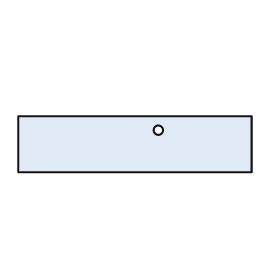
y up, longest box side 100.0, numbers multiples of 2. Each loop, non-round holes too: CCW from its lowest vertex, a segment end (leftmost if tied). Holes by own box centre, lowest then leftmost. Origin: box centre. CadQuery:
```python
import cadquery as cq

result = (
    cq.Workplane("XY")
    .moveTo(-50.0, -12.0)
    .lineTo(50.0, -12.0)
    .lineTo(50.0, 12.0)
    .lineTo(-50.0, 12.0)
    .close()
    .moveTo(10.0, 6.0)
    .circle(2.0)
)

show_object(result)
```